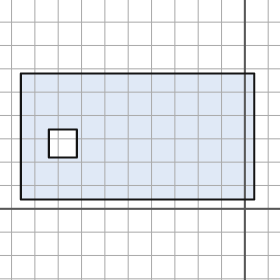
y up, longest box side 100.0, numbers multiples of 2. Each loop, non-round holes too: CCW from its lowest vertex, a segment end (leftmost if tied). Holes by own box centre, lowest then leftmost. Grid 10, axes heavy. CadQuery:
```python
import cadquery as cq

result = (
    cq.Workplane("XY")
    .moveTo(-96.0, 4.0)
    .lineTo(4.0, 4.0)
    .lineTo(4.0, 58.0)
    .lineTo(-96.0, 58.0)
    .close()
    .moveTo(-84.0, 22.0)
    .lineTo(-72.0, 22.0)
    .lineTo(-72.0, 34.0)
    .lineTo(-84.0, 34.0)
    .close()
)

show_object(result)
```